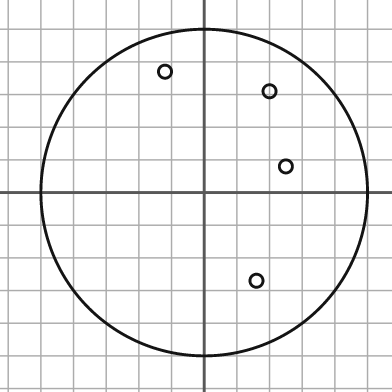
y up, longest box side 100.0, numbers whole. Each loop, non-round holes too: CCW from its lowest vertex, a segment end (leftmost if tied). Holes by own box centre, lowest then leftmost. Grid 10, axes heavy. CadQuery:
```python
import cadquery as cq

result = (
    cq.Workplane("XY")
    .moveTo(0.0, 0.0)
    .circle(50.0)
    .moveTo(16.0, -27.0)
    .circle(2.0)
    .moveTo(25.0, 8.0)
    .circle(2.0)
    .moveTo(20.0, 31.0)
    .circle(2.0)
    .moveTo(-12.0, 37.0)
    .circle(2.0)
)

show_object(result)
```